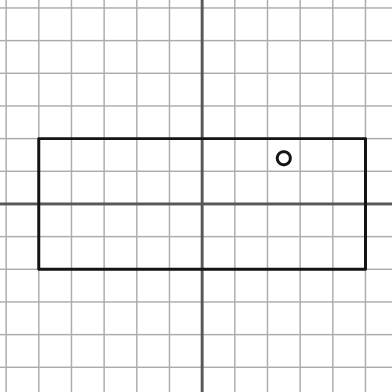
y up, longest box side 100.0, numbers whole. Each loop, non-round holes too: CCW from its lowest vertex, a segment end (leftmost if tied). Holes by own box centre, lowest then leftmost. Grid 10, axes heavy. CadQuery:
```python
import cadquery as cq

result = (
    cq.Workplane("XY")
    .moveTo(-50.0, -20.0)
    .lineTo(50.0, -20.0)
    .lineTo(50.0, 20.0)
    .lineTo(-50.0, 20.0)
    .close()
    .moveTo(25.0, 14.0)
    .circle(2.0)
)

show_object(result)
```